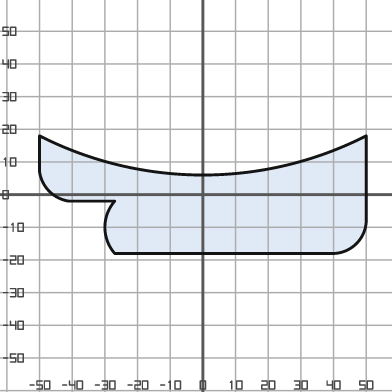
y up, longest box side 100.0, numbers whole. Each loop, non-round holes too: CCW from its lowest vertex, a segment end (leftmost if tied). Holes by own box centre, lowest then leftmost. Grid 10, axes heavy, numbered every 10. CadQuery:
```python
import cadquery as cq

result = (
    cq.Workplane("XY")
    .moveTo(-27.0, -18.0)
    .lineTo(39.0, -18.0)
    .threePointArc((47.0, -15.0), (50.0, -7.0))
    .lineTo(50.0, 18.0)
    .threePointArc((0.0, 6.0), (-50.0, 18.0))
    .lineTo(-50.0, 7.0)
    .threePointArc((-47.0, 1.0), (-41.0, -2.0))
    .lineTo(-27.0, -2.0)
    .threePointArc((-30.0, -10.0), (-27.0, -18.0))
    .close()
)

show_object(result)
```